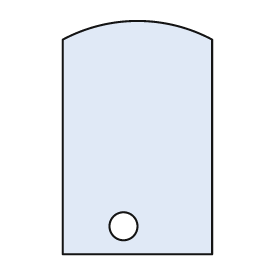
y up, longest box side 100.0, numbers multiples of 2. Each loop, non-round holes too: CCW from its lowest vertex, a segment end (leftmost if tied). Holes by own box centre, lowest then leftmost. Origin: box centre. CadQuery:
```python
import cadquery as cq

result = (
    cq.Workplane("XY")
    .moveTo(-32.0, -50.0)
    .lineTo(32.0, -50.0)
    .lineTo(32.0, 42.0)
    .threePointArc((0.0, 50.0), (-32.0, 42.0))
    .close()
    .moveTo(-6.0, -38.0)
    .circle(6.0)
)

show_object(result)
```